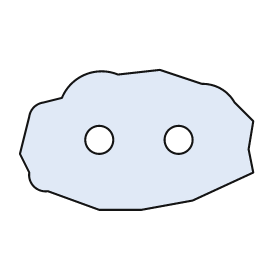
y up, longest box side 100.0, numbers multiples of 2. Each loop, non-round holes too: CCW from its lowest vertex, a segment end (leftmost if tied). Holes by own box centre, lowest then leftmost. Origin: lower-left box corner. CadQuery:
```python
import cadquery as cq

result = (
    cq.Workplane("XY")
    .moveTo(34.0, 0.0)
    .lineTo(52.0, 0.0)
    .lineTo(74.0, 4.0)
    .lineTo(100.0, 16.0)
    .lineTo(98.0, 26.0)
    .lineTo(100.0, 38.0)
    .lineTo(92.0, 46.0)
    .threePointArc((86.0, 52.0), (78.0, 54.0))
    .lineTo(60.0, 60.0)
    .lineTo(42.0, 58.0)
    .threePointArc((28.0, 58.0), (18.0, 48.0))
    .lineTo(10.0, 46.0)
    .threePointArc((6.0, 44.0), (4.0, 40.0))
    .lineTo(0.0, 24.0)
    .lineTo(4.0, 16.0)
    .threePointArc((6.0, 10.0), (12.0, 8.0))
    .close()
    .moveTo(34.0, 30.0)
    .circle(6.0)
    .moveTo(68.0, 30.0)
    .circle(6.0)
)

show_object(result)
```